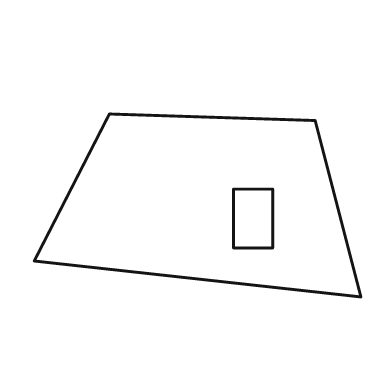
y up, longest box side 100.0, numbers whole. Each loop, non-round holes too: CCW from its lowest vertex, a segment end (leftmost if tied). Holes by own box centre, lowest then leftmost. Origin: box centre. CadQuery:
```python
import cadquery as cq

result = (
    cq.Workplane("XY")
    .moveTo(50.0, -28.0)
    .lineTo(36.0, 26.0)
    .lineTo(-27.0, 28.0)
    .lineTo(-50.0, -17.0)
    .close()
    .moveTo(11.0, -13.0)
    .lineTo(23.0, -13.0)
    .lineTo(23.0, 5.0)
    .lineTo(11.0, 5.0)
    .close()
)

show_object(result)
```